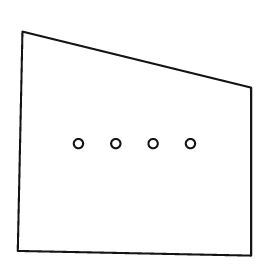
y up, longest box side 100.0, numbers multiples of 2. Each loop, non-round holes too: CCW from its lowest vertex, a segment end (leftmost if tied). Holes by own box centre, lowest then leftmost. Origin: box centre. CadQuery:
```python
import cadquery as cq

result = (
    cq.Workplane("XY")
    .moveTo(50.0, -48.0)
    .lineTo(50.0, 24.0)
    .lineTo(-48.0, 48.0)
    .lineTo(-50.0, -46.0)
    .close()
    .moveTo(-24.0, 0.0)
    .circle(2.0)
    .moveTo(-8.0, 0.0)
    .circle(2.0)
    .moveTo(8.0, 0.0)
    .circle(2.0)
    .moveTo(24.0, 0.0)
    .circle(2.0)
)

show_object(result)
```